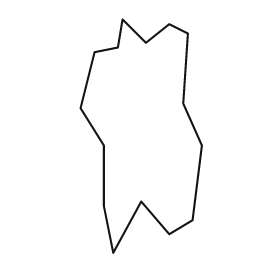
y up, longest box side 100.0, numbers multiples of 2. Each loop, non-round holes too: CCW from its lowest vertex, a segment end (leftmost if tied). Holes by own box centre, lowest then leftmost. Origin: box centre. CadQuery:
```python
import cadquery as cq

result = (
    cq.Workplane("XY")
    .moveTo(-12.0, -50.0)
    .lineTo(0.0, -28.0)
    .lineTo(12.0, -42.0)
    .lineTo(22.0, -36.0)
    .lineTo(26.0, -4.0)
    .lineTo(18.0, 14.0)
    .lineTo(20.0, 44.0)
    .lineTo(12.0, 48.0)
    .lineTo(2.0, 40.0)
    .lineTo(-8.0, 50.0)
    .lineTo(-10.0, 38.0)
    .lineTo(-20.0, 36.0)
    .lineTo(-26.0, 12.0)
    .lineTo(-16.0, -4.0)
    .lineTo(-16.0, -30.0)
    .close()
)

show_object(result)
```